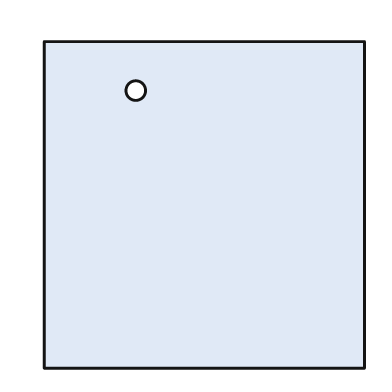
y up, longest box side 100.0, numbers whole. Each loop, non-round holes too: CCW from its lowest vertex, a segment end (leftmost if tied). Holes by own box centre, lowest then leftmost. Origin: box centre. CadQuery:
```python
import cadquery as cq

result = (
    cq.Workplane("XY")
    .moveTo(-49.0, -50.0)
    .lineTo(49.0, -50.0)
    .lineTo(49.0, 50.0)
    .lineTo(-49.0, 50.0)
    .close()
    .moveTo(-21.0, 35.0)
    .circle(3.0)
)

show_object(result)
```